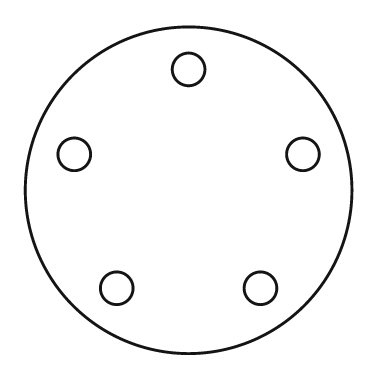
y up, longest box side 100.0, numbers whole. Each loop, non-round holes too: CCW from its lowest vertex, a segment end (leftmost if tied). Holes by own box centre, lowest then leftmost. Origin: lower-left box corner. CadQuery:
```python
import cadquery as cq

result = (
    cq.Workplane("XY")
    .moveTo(50.0, 50.0)
    .circle(50.0)
    .moveTo(28.0, 20.0)
    .circle(5.0)
    .moveTo(72.0, 20.0)
    .circle(5.0)
    .moveTo(15.0, 61.0)
    .circle(5.0)
    .moveTo(85.0, 61.0)
    .circle(5.0)
    .moveTo(50.0, 87.0)
    .circle(5.0)
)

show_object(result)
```